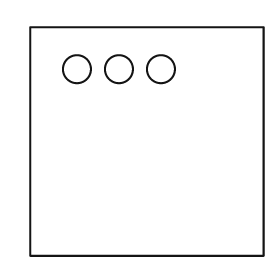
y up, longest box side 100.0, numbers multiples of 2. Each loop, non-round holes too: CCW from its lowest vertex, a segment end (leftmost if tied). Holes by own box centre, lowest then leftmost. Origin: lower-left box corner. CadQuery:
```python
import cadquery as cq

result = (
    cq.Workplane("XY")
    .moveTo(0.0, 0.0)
    .lineTo(100.0, 0.0)
    .lineTo(100.0, 98.0)
    .lineTo(0.0, 98.0)
    .close()
    .moveTo(20.0, 80.0)
    .circle(6.0)
    .moveTo(38.0, 80.0)
    .circle(6.0)
    .moveTo(56.0, 80.0)
    .circle(6.0)
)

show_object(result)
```